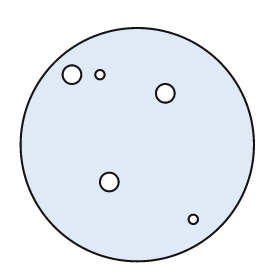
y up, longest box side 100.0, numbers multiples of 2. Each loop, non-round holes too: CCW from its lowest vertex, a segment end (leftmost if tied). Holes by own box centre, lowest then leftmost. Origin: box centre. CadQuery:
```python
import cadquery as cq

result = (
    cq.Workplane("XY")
    .moveTo(0.0, 0.0)
    .circle(50.0)
    .moveTo(24.0, -32.0)
    .circle(2.0)
    .moveTo(-12.0, -16.0)
    .circle(4.0)
    .moveTo(12.0, 22.0)
    .circle(4.0)
    .moveTo(-28.0, 30.0)
    .circle(4.0)
    .moveTo(-16.0, 30.0)
    .circle(2.0)
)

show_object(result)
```